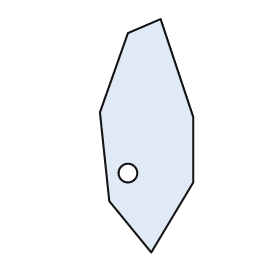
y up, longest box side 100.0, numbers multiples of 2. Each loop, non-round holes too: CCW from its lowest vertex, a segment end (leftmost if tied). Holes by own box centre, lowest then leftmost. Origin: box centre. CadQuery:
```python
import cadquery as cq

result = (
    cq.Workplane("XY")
    .moveTo(2.0, -50.0)
    .lineTo(20.0, -20.0)
    .lineTo(20.0, 8.0)
    .lineTo(6.0, 50.0)
    .lineTo(-8.0, 44.0)
    .lineTo(-20.0, 10.0)
    .lineTo(-16.0, -28.0)
    .close()
    .moveTo(-8.0, -16.0)
    .circle(4.0)
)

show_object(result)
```